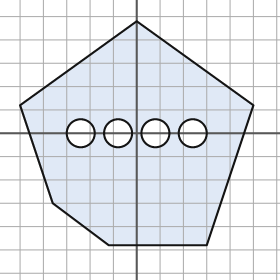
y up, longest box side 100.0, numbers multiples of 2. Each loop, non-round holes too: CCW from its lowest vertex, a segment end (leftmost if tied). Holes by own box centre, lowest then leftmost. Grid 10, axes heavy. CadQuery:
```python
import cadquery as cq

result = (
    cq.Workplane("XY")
    .moveTo(-12.0, -48.0)
    .lineTo(30.0, -48.0)
    .lineTo(50.0, 12.0)
    .lineTo(0.0, 48.0)
    .lineTo(-50.0, 12.0)
    .lineTo(-36.0, -30.0)
    .close()
    .moveTo(-24.0, 0.0)
    .circle(6.0)
    .moveTo(-8.0, 0.0)
    .circle(6.0)
    .moveTo(8.0, 0.0)
    .circle(6.0)
    .moveTo(24.0, 0.0)
    .circle(6.0)
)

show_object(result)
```